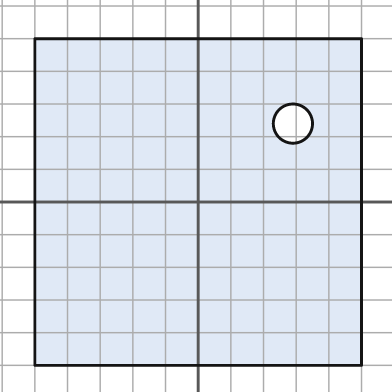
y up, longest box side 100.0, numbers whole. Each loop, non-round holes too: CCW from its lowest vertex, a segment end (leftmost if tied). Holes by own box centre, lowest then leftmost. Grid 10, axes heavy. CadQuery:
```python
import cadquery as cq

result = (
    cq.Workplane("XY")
    .moveTo(-50.0, -50.0)
    .lineTo(50.0, -50.0)
    .lineTo(50.0, 50.0)
    .lineTo(-50.0, 50.0)
    .close()
    .moveTo(29.0, 24.0)
    .circle(6.0)
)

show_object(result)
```